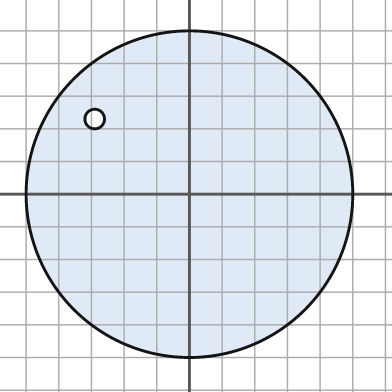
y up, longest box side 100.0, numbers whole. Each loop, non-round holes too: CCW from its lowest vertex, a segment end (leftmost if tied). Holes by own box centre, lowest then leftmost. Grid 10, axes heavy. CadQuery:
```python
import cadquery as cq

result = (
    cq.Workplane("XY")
    .moveTo(0.0, 0.0)
    .circle(50.0)
    .moveTo(-29.0, 23.0)
    .circle(3.0)
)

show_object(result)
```